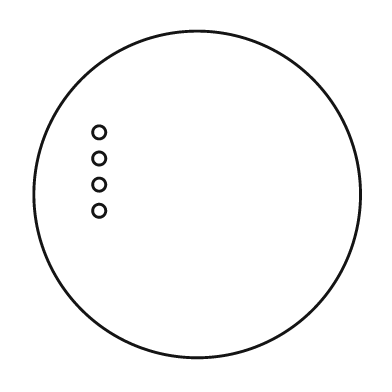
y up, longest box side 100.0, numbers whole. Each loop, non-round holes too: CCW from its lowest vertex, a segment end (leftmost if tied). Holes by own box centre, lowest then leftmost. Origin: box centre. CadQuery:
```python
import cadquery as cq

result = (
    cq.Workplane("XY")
    .moveTo(0.0, 0.0)
    .circle(50.0)
    .moveTo(-30.0, -5.0)
    .circle(2.0)
    .moveTo(-30.0, 3.0)
    .circle(2.0)
    .moveTo(-30.0, 11.0)
    .circle(2.0)
    .moveTo(-30.0, 19.0)
    .circle(2.0)
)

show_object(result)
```